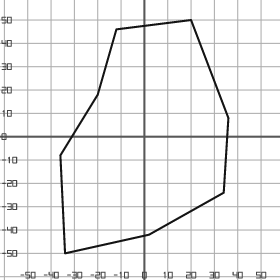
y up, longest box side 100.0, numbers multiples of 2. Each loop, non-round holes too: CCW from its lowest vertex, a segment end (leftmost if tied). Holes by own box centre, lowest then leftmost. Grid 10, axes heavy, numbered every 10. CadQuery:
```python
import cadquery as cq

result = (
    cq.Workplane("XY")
    .moveTo(-34.0, -50.0)
    .lineTo(2.0, -42.0)
    .lineTo(34.0, -24.0)
    .lineTo(36.0, 8.0)
    .lineTo(20.0, 50.0)
    .lineTo(-12.0, 46.0)
    .lineTo(-20.0, 18.0)
    .lineTo(-36.0, -8.0)
    .close()
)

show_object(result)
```